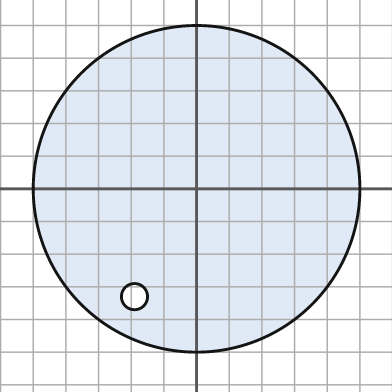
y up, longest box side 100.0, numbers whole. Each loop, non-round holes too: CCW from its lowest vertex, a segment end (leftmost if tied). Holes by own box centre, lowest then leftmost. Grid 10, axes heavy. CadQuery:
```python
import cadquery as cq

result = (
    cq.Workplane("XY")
    .moveTo(0.0, 0.0)
    .circle(50.0)
    .moveTo(-19.0, -33.0)
    .circle(4.0)
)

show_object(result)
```